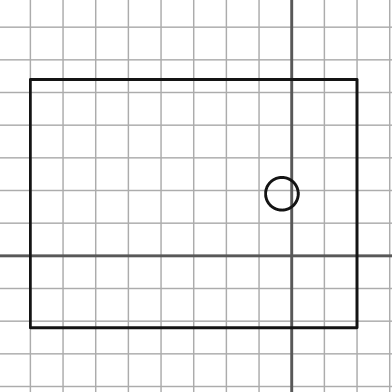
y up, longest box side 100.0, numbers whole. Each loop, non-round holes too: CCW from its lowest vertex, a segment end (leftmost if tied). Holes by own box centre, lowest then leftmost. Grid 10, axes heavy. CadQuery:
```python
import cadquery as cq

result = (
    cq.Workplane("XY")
    .moveTo(-80.0, -22.0)
    .lineTo(20.0, -22.0)
    .lineTo(20.0, 54.0)
    .lineTo(-80.0, 54.0)
    .close()
    .moveTo(-3.0, 19.0)
    .circle(5.0)
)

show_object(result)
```